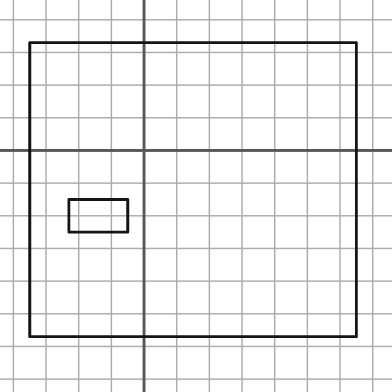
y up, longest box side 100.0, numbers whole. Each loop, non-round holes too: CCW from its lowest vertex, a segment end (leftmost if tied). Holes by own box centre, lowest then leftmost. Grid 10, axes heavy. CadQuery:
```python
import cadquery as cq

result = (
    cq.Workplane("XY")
    .moveTo(-35.0, -57.0)
    .lineTo(65.0, -57.0)
    .lineTo(65.0, 33.0)
    .lineTo(-35.0, 33.0)
    .close()
    .moveTo(-23.0, -25.0)
    .lineTo(-5.0, -25.0)
    .lineTo(-5.0, -15.0)
    .lineTo(-23.0, -15.0)
    .close()
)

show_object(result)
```